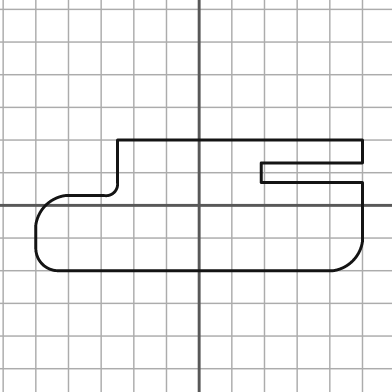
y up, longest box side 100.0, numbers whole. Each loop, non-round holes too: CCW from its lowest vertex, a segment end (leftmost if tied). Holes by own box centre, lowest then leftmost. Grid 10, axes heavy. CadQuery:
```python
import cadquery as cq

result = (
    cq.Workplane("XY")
    .moveTo(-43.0, -20.0)
    .lineTo(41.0, -20.0)
    .threePointArc((47.0, -17.0), (50.0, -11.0))
    .lineTo(50.0, 7.0)
    .lineTo(19.0, 7.0)
    .lineTo(19.0, 13.0)
    .lineTo(50.0, 13.0)
    .lineTo(50.0, 20.0)
    .lineTo(-25.0, 20.0)
    .lineTo(-25.0, 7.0)
    .threePointArc((-26.0, 4.0), (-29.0, 3.0))
    .lineTo(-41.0, 3.0)
    .threePointArc((-47.0, 0.0), (-50.0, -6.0))
    .lineTo(-50.0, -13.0)
    .threePointArc((-48.0, -18.0), (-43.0, -20.0))
    .close()
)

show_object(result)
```